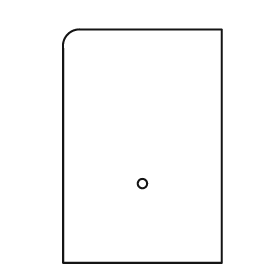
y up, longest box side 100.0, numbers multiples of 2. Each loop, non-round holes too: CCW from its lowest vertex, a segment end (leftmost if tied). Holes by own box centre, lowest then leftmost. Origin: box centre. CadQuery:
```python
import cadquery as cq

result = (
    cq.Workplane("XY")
    .moveTo(-34.0, -50.0)
    .lineTo(34.0, -50.0)
    .lineTo(34.0, 50.0)
    .lineTo(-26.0, 50.0)
    .threePointArc((-32.0, 48.0), (-34.0, 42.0))
    .close()
    .moveTo(0.0, -16.0)
    .circle(2.0)
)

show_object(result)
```